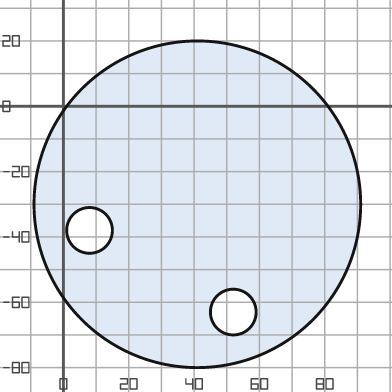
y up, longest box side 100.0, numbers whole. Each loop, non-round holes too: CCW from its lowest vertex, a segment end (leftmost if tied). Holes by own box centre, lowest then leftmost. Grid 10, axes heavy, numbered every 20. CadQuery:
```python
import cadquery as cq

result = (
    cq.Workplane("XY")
    .moveTo(41.0, -30.0)
    .circle(50.0)
    .moveTo(52.0, -63.0)
    .circle(7.0)
    .moveTo(8.0, -38.0)
    .circle(7.0)
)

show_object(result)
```